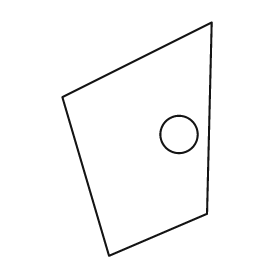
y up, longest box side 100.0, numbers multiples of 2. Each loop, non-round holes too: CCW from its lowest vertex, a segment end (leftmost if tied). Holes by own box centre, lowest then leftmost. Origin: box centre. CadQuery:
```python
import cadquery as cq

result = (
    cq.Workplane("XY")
    .moveTo(-12.0, -50.0)
    .lineTo(30.0, -32.0)
    .lineTo(32.0, 50.0)
    .lineTo(-32.0, 18.0)
    .close()
    .moveTo(18.0, 2.0)
    .circle(8.0)
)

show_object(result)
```